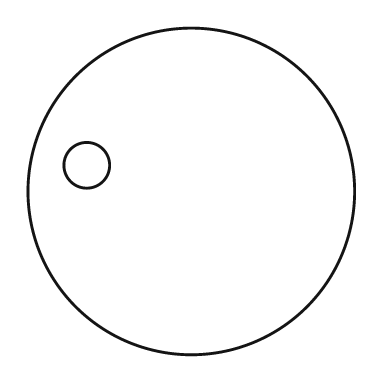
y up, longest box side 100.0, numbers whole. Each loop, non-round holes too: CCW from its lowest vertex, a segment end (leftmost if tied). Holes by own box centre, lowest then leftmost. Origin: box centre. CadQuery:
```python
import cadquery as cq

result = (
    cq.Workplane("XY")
    .moveTo(0.0, 0.0)
    .circle(50.0)
    .moveTo(-32.0, 8.0)
    .circle(7.0)
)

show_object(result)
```